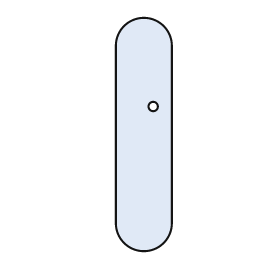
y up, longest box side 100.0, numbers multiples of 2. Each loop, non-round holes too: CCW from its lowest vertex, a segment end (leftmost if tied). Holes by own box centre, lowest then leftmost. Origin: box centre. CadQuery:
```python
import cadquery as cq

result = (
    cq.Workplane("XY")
    .moveTo(-12.0, -38.0)
    .threePointArc((0.0, -50.0), (12.0, -38.0))
    .lineTo(12.0, 38.0)
    .threePointArc((0.0, 50.0), (-12.0, 38.0))
    .close()
    .moveTo(4.0, 12.0)
    .circle(2.0)
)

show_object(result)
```